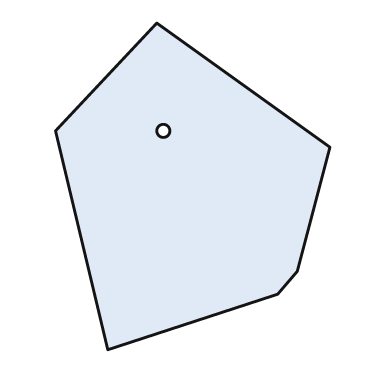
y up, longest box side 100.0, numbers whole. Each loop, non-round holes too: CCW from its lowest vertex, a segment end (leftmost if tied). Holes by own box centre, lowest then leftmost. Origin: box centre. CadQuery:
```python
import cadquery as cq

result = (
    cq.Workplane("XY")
    .moveTo(-26.0, -50.0)
    .lineTo(26.0, -33.0)
    .lineTo(32.0, -26.0)
    .lineTo(42.0, 12.0)
    .lineTo(-11.0, 50.0)
    .lineTo(-42.0, 17.0)
    .close()
    .moveTo(-9.0, 17.0)
    .circle(2.0)
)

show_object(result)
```